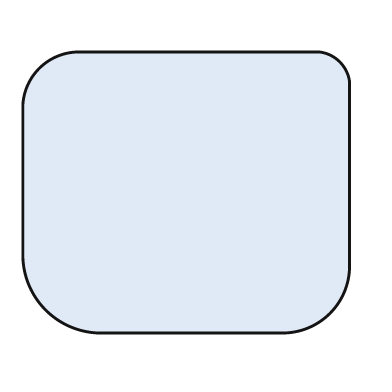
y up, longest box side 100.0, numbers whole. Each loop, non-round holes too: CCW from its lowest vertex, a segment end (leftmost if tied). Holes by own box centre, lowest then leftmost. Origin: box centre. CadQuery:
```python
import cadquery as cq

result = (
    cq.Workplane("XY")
    .moveTo(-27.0, -43.0)
    .lineTo(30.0, -43.0)
    .threePointArc((44.0, -37.0), (50.0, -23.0))
    .lineTo(50.0, 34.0)
    .threePointArc((47.0, 40.0), (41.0, 43.0))
    .lineTo(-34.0, 43.0)
    .threePointArc((-45.0, 38.0), (-50.0, 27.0))
    .lineTo(-50.0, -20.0)
    .threePointArc((-43.0, -36.0), (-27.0, -43.0))
    .close()
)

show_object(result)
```